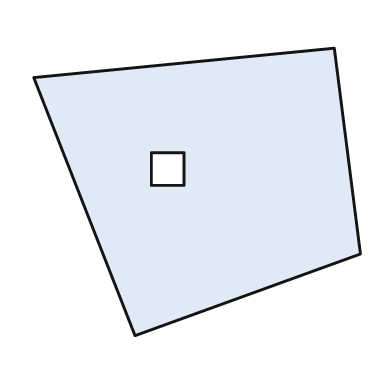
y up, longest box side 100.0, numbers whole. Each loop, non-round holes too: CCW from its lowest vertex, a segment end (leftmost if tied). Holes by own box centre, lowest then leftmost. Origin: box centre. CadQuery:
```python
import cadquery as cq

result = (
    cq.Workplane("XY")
    .moveTo(-19.0, -44.0)
    .lineTo(50.0, -19.0)
    .lineTo(42.0, 44.0)
    .lineTo(-50.0, 35.0)
    .close()
    .moveTo(-14.0, 2.0)
    .lineTo(-4.0, 2.0)
    .lineTo(-4.0, 12.0)
    .lineTo(-14.0, 12.0)
    .close()
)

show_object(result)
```